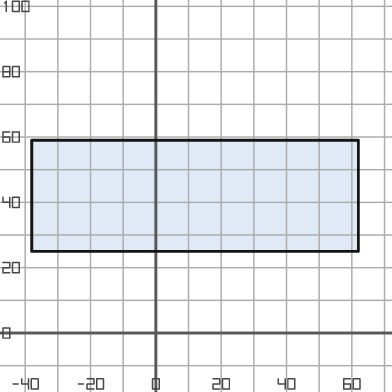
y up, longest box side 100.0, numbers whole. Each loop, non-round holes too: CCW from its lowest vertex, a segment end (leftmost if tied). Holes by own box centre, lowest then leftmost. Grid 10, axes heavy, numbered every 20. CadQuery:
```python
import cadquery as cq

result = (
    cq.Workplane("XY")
    .moveTo(-38.0, 25.0)
    .lineTo(62.0, 25.0)
    .lineTo(62.0, 59.0)
    .lineTo(-38.0, 59.0)
    .close()
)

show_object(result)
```